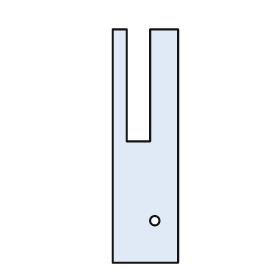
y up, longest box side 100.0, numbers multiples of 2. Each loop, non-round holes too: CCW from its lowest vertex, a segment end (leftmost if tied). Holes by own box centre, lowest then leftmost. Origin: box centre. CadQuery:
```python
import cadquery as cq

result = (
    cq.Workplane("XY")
    .moveTo(-14.0, -50.0)
    .lineTo(14.0, -50.0)
    .lineTo(14.0, 50.0)
    .lineTo(2.0, 50.0)
    .lineTo(2.0, 2.0)
    .lineTo(-8.0, 2.0)
    .lineTo(-8.0, 50.0)
    .lineTo(-14.0, 50.0)
    .close()
    .moveTo(4.0, -32.0)
    .circle(2.0)
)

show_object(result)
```